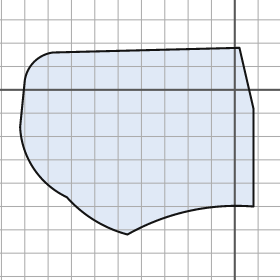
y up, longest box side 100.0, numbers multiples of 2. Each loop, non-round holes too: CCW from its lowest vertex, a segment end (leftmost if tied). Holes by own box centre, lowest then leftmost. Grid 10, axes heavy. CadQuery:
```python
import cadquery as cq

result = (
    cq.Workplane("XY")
    .moveTo(-46.0, -62.0)
    .threePointArc((-20.0, -52.0), (8.0, -50.0))
    .lineTo(8.0, -8.0)
    .lineTo(2.0, 18.0)
    .lineTo(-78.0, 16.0)
    .threePointArc((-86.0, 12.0), (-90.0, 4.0))
    .lineTo(-92.0, -16.0)
    .threePointArc((-86.0, -34.0), (-72.0, -46.0))
    .threePointArc((-60.0, -56.0), (-46.0, -62.0))
    .close()
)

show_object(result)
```